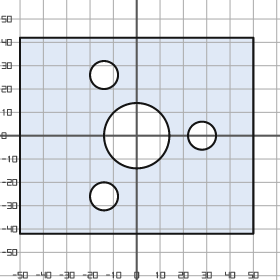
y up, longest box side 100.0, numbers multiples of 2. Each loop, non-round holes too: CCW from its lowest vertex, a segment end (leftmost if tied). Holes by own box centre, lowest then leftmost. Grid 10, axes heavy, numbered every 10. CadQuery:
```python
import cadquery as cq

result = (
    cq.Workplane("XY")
    .moveTo(-50.0, -42.0)
    .lineTo(50.0, -42.0)
    .lineTo(50.0, 42.0)
    .lineTo(-50.0, 42.0)
    .close()
    .moveTo(-14.0, -26.0)
    .circle(6.0)
    .moveTo(0.0, 0.0)
    .circle(14.0)
    .moveTo(28.0, 0.0)
    .circle(6.0)
    .moveTo(-14.0, 26.0)
    .circle(6.0)
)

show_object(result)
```